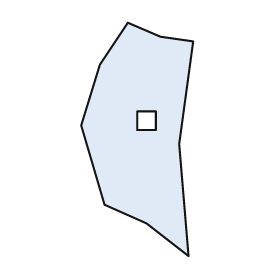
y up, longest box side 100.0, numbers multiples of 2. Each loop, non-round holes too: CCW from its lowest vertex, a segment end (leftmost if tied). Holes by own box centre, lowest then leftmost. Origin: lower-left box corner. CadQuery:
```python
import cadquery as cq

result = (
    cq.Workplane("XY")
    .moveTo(46.0, 0.0)
    .lineTo(42.0, 48.0)
    .lineTo(48.0, 92.0)
    .lineTo(34.0, 94.0)
    .lineTo(20.0, 100.0)
    .lineTo(8.0, 82.0)
    .lineTo(0.0, 56.0)
    .lineTo(10.0, 22.0)
    .lineTo(28.0, 14.0)
    .close()
    .moveTo(24.0, 54.0)
    .lineTo(32.0, 54.0)
    .lineTo(32.0, 62.0)
    .lineTo(24.0, 62.0)
    .close()
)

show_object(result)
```